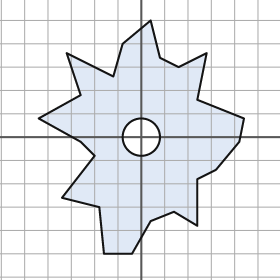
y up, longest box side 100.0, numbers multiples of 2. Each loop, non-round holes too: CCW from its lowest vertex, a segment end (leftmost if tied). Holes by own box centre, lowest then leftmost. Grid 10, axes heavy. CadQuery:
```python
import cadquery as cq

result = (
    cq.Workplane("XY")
    .moveTo(-16.0, -50.0)
    .lineTo(-4.0, -50.0)
    .lineTo(4.0, -36.0)
    .lineTo(14.0, -32.0)
    .lineTo(24.0, -38.0)
    .lineTo(24.0, -18.0)
    .lineTo(32.0, -14.0)
    .lineTo(42.0, -2.0)
    .lineTo(44.0, 8.0)
    .lineTo(24.0, 16.0)
    .lineTo(28.0, 36.0)
    .lineTo(16.0, 30.0)
    .lineTo(8.0, 34.0)
    .lineTo(4.0, 50.0)
    .lineTo(-8.0, 40.0)
    .lineTo(-12.0, 26.0)
    .lineTo(-32.0, 36.0)
    .lineTo(-26.0, 18.0)
    .lineTo(-44.0, 8.0)
    .lineTo(-26.0, -2.0)
    .lineTo(-20.0, -8.0)
    .lineTo(-34.0, -26.0)
    .lineTo(-18.0, -30.0)
    .close()
    .moveTo(0.0, 0.0)
    .circle(8.0)
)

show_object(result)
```